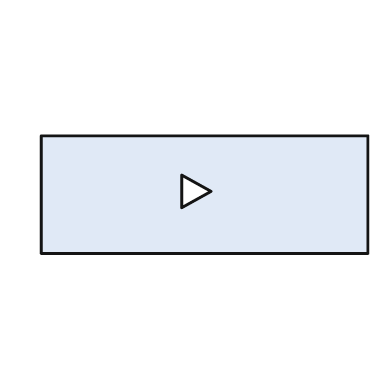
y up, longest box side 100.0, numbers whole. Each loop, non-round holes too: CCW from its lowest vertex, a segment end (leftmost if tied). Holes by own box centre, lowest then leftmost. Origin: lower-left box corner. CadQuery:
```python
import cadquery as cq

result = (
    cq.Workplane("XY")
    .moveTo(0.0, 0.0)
    .lineTo(100.0, 0.0)
    .lineTo(100.0, 36.0)
    .lineTo(0.0, 36.0)
    .close()
    .moveTo(43.0, 14.0)
    .lineTo(52.0, 19.0)
    .lineTo(43.0, 24.0)
    .close()
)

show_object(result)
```